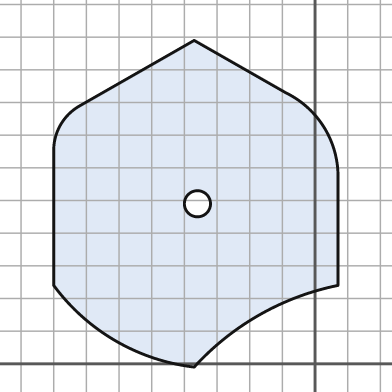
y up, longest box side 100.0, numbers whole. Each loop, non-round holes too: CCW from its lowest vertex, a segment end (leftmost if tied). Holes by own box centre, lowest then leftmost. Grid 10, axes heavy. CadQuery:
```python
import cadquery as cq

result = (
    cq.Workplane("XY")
    .moveTo(-37.0, -1.0)
    .threePointArc((-17.0, 15.0), (7.0, 24.0))
    .lineTo(7.0, 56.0)
    .threePointArc((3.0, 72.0), (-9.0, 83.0))
    .lineTo(-37.0, 99.0)
    .lineTo(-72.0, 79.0)
    .threePointArc((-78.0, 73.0), (-80.0, 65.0))
    .lineTo(-80.0, 24.0)
    .threePointArc((-61.0, 7.0), (-37.0, -1.0))
    .close()
    .moveTo(-36.0, 49.0)
    .circle(4.0)
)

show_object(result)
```